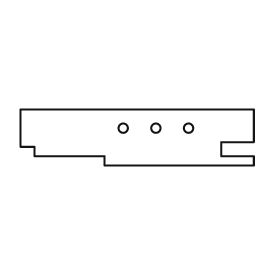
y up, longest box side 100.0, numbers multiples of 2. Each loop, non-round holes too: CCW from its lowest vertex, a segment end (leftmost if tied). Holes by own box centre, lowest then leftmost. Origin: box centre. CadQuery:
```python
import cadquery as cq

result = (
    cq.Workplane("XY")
    .moveTo(-14.0, -12.0)
    .lineTo(50.0, -12.0)
    .lineTo(50.0, -8.0)
    .lineTo(36.0, -8.0)
    .lineTo(36.0, -2.0)
    .lineTo(50.0, -2.0)
    .lineTo(50.0, 12.0)
    .lineTo(-50.0, 12.0)
    .lineTo(-50.0, -4.0)
    .lineTo(-44.0, -4.0)
    .lineTo(-44.0, -8.0)
    .lineTo(-14.0, -8.0)
    .close()
    .moveTo(-6.0, 4.0)
    .circle(2.0)
    .moveTo(8.0, 4.0)
    .circle(2.0)
    .moveTo(22.0, 4.0)
    .circle(2.0)
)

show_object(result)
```